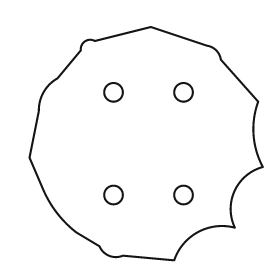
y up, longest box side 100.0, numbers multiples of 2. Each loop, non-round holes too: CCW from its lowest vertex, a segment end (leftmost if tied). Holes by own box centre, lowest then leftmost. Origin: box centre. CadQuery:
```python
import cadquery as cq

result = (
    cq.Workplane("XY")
    .moveTo(12.0, -50.0)
    .threePointArc((22.0, -38.0), (38.0, -36.0))
    .threePointArc((38.0, -20.0), (50.0, -10.0))
    .threePointArc((46.0, 4.0), (48.0, 18.0))
    .lineTo(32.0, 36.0)
    .threePointArc((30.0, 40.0), (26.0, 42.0))
    .lineTo(2.0, 50.0)
    .lineTo(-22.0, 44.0)
    .threePointArc((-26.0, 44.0), (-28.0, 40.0))
    .lineTo(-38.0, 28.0)
    .threePointArc((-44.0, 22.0), (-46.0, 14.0))
    .lineTo(-50.0, -6.0)
    .lineTo(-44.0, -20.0)
    .threePointArc((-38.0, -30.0), (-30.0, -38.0))
    .lineTo(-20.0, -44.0)
    .threePointArc((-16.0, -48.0), (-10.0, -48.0))
    .close()
    .moveTo(-14.0, -22.0)
    .circle(4.0)
    .moveTo(16.0, -22.0)
    .circle(4.0)
    .moveTo(-14.0, 22.0)
    .circle(4.0)
    .moveTo(16.0, 22.0)
    .circle(4.0)
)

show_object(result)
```